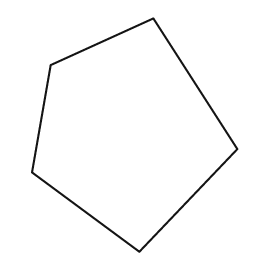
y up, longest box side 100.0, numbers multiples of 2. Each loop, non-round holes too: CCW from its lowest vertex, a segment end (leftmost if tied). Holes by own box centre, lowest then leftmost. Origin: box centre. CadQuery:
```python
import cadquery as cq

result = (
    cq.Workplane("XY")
    .moveTo(2.0, -50.0)
    .lineTo(44.0, -6.0)
    .lineTo(8.0, 50.0)
    .lineTo(-36.0, 30.0)
    .lineTo(-44.0, -16.0)
    .close()
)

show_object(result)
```